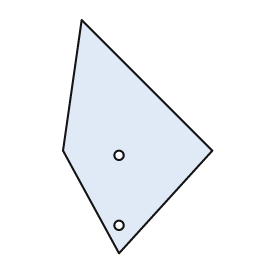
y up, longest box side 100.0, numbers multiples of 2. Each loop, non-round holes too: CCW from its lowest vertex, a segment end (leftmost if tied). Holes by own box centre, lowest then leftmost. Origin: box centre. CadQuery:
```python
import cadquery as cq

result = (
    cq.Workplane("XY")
    .moveTo(-8.0, -50.0)
    .lineTo(32.0, -6.0)
    .lineTo(-24.0, 50.0)
    .lineTo(-32.0, -6.0)
    .close()
    .moveTo(-8.0, -38.0)
    .circle(2.0)
    .moveTo(-8.0, -8.0)
    .circle(2.0)
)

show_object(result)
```